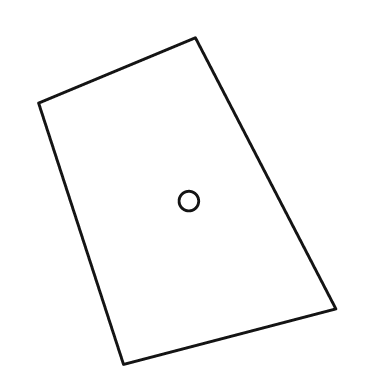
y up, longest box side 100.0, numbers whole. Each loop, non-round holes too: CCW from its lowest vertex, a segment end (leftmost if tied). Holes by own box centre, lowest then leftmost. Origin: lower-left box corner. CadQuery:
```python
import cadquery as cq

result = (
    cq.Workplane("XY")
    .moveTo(26.0, 0.0)
    .lineTo(91.0, 17.0)
    .lineTo(48.0, 100.0)
    .lineTo(0.0, 80.0)
    .close()
    .moveTo(46.0, 50.0)
    .circle(3.0)
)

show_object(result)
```